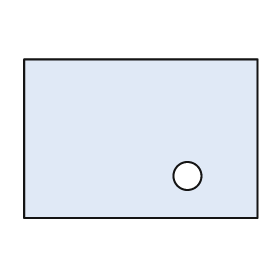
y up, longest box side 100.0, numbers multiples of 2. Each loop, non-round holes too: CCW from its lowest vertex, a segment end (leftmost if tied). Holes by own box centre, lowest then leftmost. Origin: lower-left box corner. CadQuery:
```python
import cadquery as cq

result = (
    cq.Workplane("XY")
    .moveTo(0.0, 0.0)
    .lineTo(100.0, 0.0)
    .lineTo(100.0, 68.0)
    .lineTo(0.0, 68.0)
    .close()
    .moveTo(70.0, 18.0)
    .circle(6.0)
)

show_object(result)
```